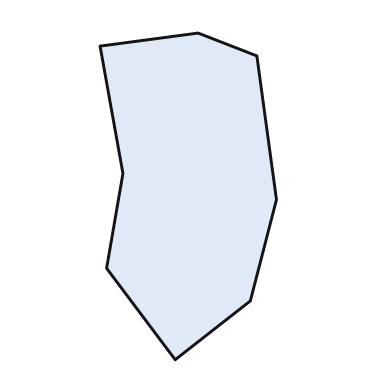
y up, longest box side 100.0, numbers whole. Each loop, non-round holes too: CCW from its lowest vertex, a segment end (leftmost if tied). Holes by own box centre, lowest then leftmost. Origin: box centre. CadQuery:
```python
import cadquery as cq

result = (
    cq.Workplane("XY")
    .moveTo(-4.0, -50.0)
    .lineTo(19.0, -32.0)
    .lineTo(27.0, -1.0)
    .lineTo(21.0, 43.0)
    .lineTo(3.0, 50.0)
    .lineTo(-27.0, 46.0)
    .lineTo(-20.0, 7.0)
    .lineTo(-25.0, -22.0)
    .close()
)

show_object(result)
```